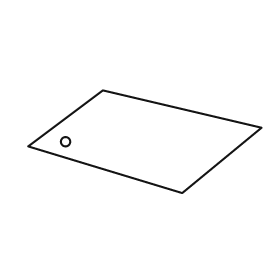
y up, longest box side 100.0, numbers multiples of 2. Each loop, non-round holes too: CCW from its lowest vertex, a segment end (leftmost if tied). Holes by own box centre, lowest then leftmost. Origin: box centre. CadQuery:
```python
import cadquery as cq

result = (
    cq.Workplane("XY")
    .moveTo(16.0, -22.0)
    .lineTo(50.0, 6.0)
    .lineTo(-18.0, 22.0)
    .lineTo(-50.0, -2.0)
    .close()
    .moveTo(-34.0, 0.0)
    .circle(2.0)
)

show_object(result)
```